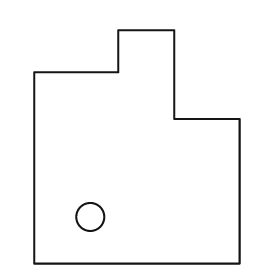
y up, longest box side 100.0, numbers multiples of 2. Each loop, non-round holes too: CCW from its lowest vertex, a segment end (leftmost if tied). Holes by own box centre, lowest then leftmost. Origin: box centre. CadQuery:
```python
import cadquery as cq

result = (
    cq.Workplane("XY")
    .moveTo(-44.0, -50.0)
    .lineTo(44.0, -50.0)
    .lineTo(44.0, 12.0)
    .lineTo(16.0, 12.0)
    .lineTo(16.0, 50.0)
    .lineTo(-8.0, 50.0)
    .lineTo(-8.0, 32.0)
    .lineTo(-44.0, 32.0)
    .close()
    .moveTo(-20.0, -30.0)
    .circle(6.0)
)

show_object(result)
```